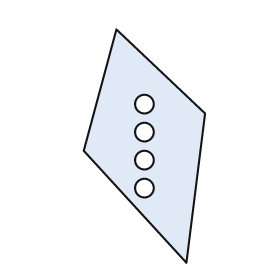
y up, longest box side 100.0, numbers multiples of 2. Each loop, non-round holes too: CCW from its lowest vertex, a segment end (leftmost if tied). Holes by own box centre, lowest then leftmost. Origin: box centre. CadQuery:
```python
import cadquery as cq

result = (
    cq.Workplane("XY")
    .moveTo(18.0, -50.0)
    .lineTo(26.0, 14.0)
    .lineTo(-12.0, 50.0)
    .lineTo(-26.0, -2.0)
    .close()
    .moveTo(0.0, -18.0)
    .circle(4.0)
    .moveTo(0.0, -6.0)
    .circle(4.0)
    .moveTo(0.0, 6.0)
    .circle(4.0)
    .moveTo(0.0, 18.0)
    .circle(4.0)
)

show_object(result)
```